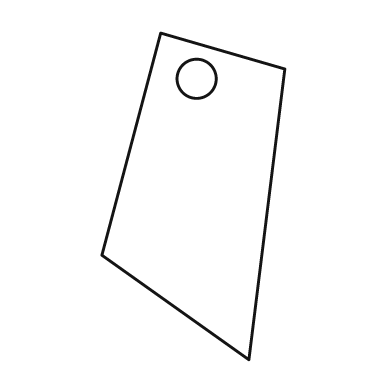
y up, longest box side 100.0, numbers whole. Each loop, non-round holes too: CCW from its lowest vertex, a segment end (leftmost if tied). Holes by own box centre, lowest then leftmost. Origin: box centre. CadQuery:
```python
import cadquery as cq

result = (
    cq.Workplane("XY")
    .moveTo(17.0, -50.0)
    .lineTo(28.0, 39.0)
    .lineTo(-10.0, 50.0)
    .lineTo(-28.0, -18.0)
    .close()
    .moveTo(1.0, 36.0)
    .circle(6.0)
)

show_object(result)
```